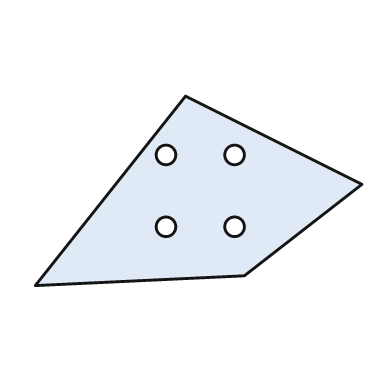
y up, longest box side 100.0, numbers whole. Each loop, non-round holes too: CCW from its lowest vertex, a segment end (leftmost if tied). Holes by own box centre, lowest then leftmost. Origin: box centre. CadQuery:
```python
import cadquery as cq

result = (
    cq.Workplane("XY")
    .moveTo(-50.0, -29.0)
    .lineTo(14.0, -26.0)
    .lineTo(50.0, 2.0)
    .lineTo(-4.0, 29.0)
    .close()
    .moveTo(-10.0, -11.0)
    .circle(3.0)
    .moveTo(11.0, -11.0)
    .circle(3.0)
    .moveTo(-10.0, 11.0)
    .circle(3.0)
    .moveTo(11.0, 11.0)
    .circle(3.0)
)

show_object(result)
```